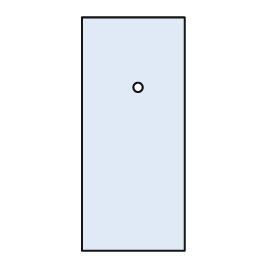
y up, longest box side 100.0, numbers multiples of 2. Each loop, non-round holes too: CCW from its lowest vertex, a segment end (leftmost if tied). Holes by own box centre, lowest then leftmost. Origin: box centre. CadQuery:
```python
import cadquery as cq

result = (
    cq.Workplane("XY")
    .moveTo(-22.0, -50.0)
    .lineTo(22.0, -50.0)
    .lineTo(22.0, 50.0)
    .lineTo(-22.0, 50.0)
    .close()
    .moveTo(2.0, 20.0)
    .circle(2.0)
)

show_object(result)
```